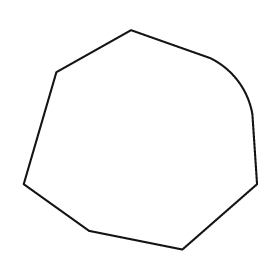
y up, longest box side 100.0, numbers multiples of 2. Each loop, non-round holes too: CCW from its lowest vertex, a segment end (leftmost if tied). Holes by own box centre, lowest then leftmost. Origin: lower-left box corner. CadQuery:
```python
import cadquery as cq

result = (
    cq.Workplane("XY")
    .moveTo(68.0, 0.0)
    .lineTo(100.0, 28.0)
    .lineTo(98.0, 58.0)
    .threePointArc((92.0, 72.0), (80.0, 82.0))
    .lineTo(46.0, 94.0)
    .lineTo(14.0, 76.0)
    .lineTo(0.0, 28.0)
    .lineTo(28.0, 8.0)
    .close()
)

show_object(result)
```